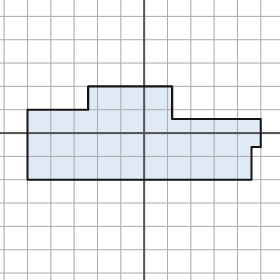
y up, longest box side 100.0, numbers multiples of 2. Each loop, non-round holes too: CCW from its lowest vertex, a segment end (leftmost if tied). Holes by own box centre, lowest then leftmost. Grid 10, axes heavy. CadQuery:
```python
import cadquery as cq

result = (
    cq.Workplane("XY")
    .moveTo(-50.0, -20.0)
    .lineTo(46.0, -20.0)
    .lineTo(46.0, -6.0)
    .lineTo(50.0, -6.0)
    .lineTo(50.0, 6.0)
    .lineTo(12.0, 6.0)
    .lineTo(12.0, 20.0)
    .lineTo(-24.0, 20.0)
    .lineTo(-24.0, 10.0)
    .lineTo(-50.0, 10.0)
    .close()
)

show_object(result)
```